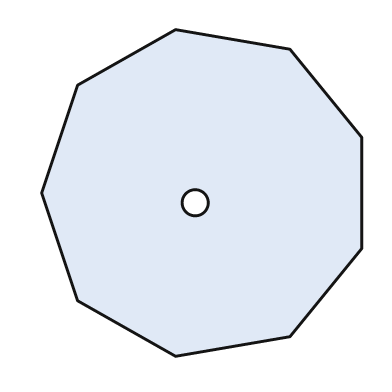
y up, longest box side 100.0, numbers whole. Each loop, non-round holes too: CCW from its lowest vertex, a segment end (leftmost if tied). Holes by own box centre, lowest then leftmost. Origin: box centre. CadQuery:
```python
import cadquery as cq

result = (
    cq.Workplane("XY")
    .moveTo(-8.0, -50.0)
    .lineTo(27.0, -44.0)
    .lineTo(49.0, -17.0)
    .lineTo(49.0, 17.0)
    .lineTo(27.0, 44.0)
    .lineTo(-8.0, 50.0)
    .lineTo(-38.0, 33.0)
    .lineTo(-49.0, 0.0)
    .lineTo(-38.0, -33.0)
    .close()
    .moveTo(-2.0, -3.0)
    .circle(4.0)
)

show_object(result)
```